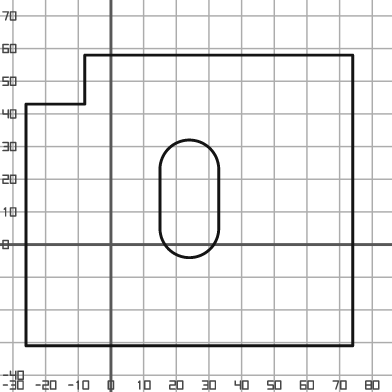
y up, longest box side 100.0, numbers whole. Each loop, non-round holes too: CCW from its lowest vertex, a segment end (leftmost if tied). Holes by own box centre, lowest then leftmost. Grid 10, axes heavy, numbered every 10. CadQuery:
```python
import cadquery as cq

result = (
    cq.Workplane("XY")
    .moveTo(-26.0, -31.0)
    .lineTo(74.0, -31.0)
    .lineTo(74.0, 58.0)
    .lineTo(-8.0, 58.0)
    .lineTo(-8.0, 43.0)
    .lineTo(-26.0, 43.0)
    .close()
    .moveTo(15.0, 5.0)
    .threePointArc((24.0, -4.0), (33.0, 5.0))
    .lineTo(33.0, 23.0)
    .threePointArc((24.0, 32.0), (15.0, 23.0))
    .close()
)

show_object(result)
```